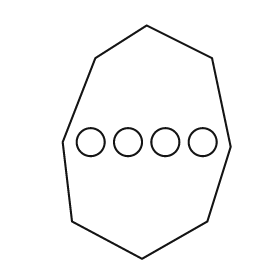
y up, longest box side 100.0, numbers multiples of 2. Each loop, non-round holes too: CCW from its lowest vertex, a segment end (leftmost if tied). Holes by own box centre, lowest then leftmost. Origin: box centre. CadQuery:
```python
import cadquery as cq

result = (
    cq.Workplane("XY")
    .moveTo(-2.0, -50.0)
    .lineTo(26.0, -34.0)
    .lineTo(36.0, -2.0)
    .lineTo(28.0, 36.0)
    .lineTo(0.0, 50.0)
    .lineTo(-22.0, 36.0)
    .lineTo(-36.0, 0.0)
    .lineTo(-32.0, -34.0)
    .close()
    .moveTo(-24.0, 0.0)
    .circle(6.0)
    .moveTo(-8.0, 0.0)
    .circle(6.0)
    .moveTo(8.0, 0.0)
    .circle(6.0)
    .moveTo(24.0, 0.0)
    .circle(6.0)
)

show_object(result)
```